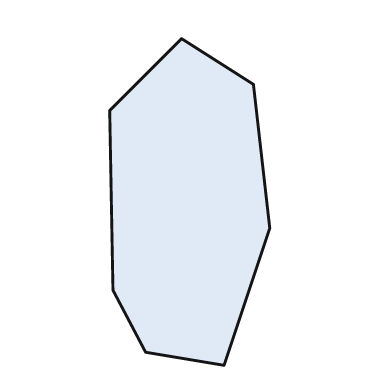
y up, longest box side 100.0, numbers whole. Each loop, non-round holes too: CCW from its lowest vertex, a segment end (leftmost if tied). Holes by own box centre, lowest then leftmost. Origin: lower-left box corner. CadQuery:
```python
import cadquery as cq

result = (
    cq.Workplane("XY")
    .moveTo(35.0, 0.0)
    .lineTo(49.0, 42.0)
    .lineTo(44.0, 86.0)
    .lineTo(22.0, 100.0)
    .lineTo(0.0, 78.0)
    .lineTo(1.0, 23.0)
    .lineTo(11.0, 4.0)
    .close()
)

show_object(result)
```